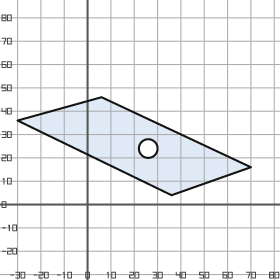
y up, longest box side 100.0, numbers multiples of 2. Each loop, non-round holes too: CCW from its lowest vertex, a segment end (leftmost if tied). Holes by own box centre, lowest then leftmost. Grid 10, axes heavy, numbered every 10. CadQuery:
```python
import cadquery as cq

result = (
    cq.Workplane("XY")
    .moveTo(36.0, 4.0)
    .lineTo(70.0, 16.0)
    .lineTo(6.0, 46.0)
    .lineTo(-30.0, 36.0)
    .close()
    .moveTo(26.0, 24.0)
    .circle(4.0)
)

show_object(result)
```